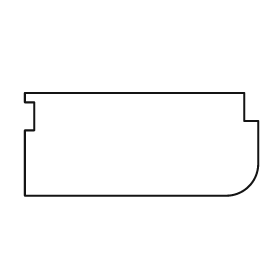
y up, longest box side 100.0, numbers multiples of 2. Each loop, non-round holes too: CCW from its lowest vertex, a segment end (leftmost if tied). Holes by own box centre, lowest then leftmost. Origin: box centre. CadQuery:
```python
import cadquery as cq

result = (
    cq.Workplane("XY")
    .moveTo(-50.0, -22.0)
    .lineTo(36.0, -22.0)
    .threePointArc((46.0, -18.0), (50.0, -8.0))
    .lineTo(50.0, 10.0)
    .lineTo(44.0, 10.0)
    .lineTo(44.0, 22.0)
    .lineTo(-50.0, 22.0)
    .lineTo(-50.0, 18.0)
    .lineTo(-46.0, 18.0)
    .lineTo(-46.0, 6.0)
    .lineTo(-50.0, 6.0)
    .close()
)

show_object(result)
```